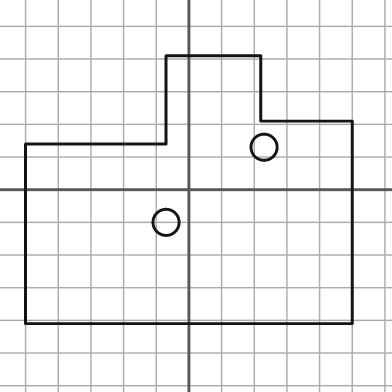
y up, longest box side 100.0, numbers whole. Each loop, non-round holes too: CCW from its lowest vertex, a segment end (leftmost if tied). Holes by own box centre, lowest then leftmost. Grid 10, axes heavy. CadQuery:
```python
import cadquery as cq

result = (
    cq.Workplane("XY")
    .moveTo(-50.0, -41.0)
    .lineTo(50.0, -41.0)
    .lineTo(50.0, 21.0)
    .lineTo(22.0, 21.0)
    .lineTo(22.0, 41.0)
    .lineTo(-7.0, 41.0)
    .lineTo(-7.0, 14.0)
    .lineTo(-50.0, 14.0)
    .close()
    .moveTo(-7.0, -10.0)
    .circle(4.0)
    .moveTo(23.0, 13.0)
    .circle(4.0)
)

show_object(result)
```